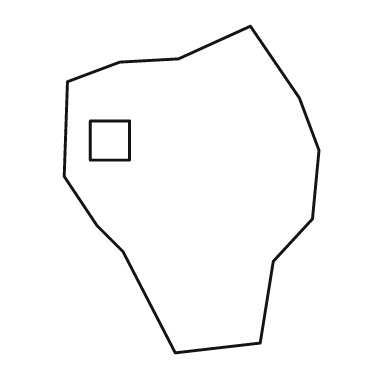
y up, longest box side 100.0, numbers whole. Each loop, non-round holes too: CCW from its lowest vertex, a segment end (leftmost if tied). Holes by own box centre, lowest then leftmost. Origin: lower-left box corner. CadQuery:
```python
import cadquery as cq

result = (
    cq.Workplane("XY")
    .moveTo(34.0, 0.0)
    .lineTo(60.0, 3.0)
    .lineTo(64.0, 28.0)
    .lineTo(76.0, 41.0)
    .lineTo(78.0, 62.0)
    .lineTo(72.0, 78.0)
    .lineTo(57.0, 100.0)
    .lineTo(35.0, 90.0)
    .lineTo(17.0, 89.0)
    .lineTo(1.0, 83.0)
    .lineTo(0.0, 54.0)
    .lineTo(10.0, 39.0)
    .lineTo(18.0, 31.0)
    .close()
    .moveTo(8.0, 59.0)
    .lineTo(20.0, 59.0)
    .lineTo(20.0, 71.0)
    .lineTo(8.0, 71.0)
    .close()
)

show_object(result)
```